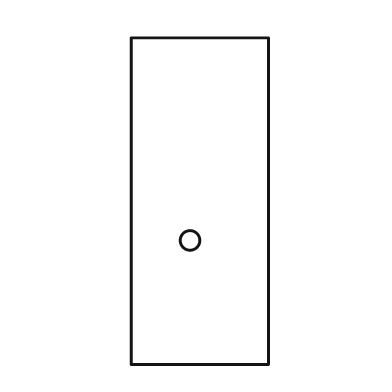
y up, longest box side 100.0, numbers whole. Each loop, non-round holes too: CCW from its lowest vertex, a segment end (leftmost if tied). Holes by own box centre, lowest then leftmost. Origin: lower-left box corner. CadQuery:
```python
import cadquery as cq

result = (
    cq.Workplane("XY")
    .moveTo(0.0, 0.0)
    .lineTo(42.0, 0.0)
    .lineTo(42.0, 100.0)
    .lineTo(0.0, 100.0)
    .close()
    .moveTo(18.0, 38.0)
    .circle(3.0)
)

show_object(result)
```